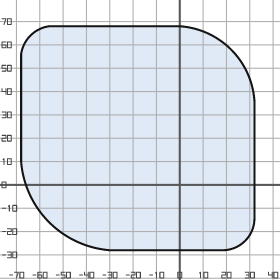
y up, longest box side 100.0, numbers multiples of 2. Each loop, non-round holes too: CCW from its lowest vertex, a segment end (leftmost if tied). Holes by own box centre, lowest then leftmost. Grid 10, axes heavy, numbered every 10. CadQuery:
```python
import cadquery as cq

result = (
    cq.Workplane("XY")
    .moveTo(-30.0, -28.0)
    .lineTo(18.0, -28.0)
    .threePointArc((28.0, -24.0), (32.0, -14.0))
    .lineTo(32.0, 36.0)
    .threePointArc((22.0, 58.0), (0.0, 68.0))
    .lineTo(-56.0, 68.0)
    .threePointArc((-64.0, 64.0), (-68.0, 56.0))
    .lineTo(-68.0, 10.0)
    .threePointArc((-56.0, -16.0), (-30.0, -28.0))
    .close()
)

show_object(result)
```